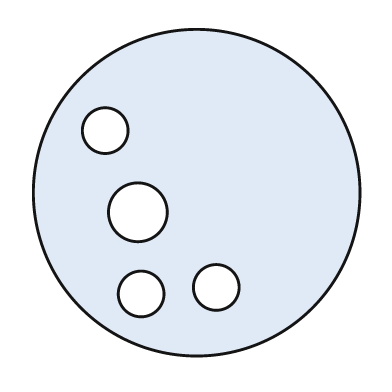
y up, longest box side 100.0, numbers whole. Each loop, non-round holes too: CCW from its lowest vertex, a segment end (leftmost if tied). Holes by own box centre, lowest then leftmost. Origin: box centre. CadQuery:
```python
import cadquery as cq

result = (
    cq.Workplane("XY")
    .moveTo(0.0, 0.0)
    .circle(50.0)
    .moveTo(-17.0, -31.0)
    .circle(7.0)
    .moveTo(6.0, -29.0)
    .circle(7.0)
    .moveTo(-18.0, -6.0)
    .circle(9.0)
    .moveTo(-28.0, 19.0)
    .circle(7.0)
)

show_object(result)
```